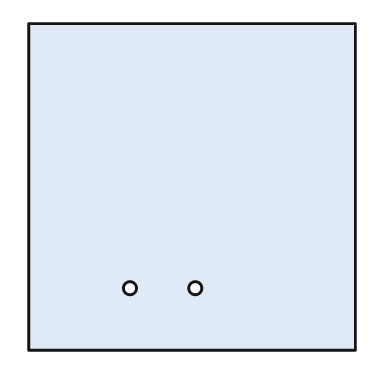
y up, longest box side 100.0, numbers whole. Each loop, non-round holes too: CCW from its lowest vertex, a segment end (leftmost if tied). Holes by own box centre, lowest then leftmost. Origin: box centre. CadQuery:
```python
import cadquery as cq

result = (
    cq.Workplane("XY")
    .moveTo(-50.0, -50.0)
    .lineTo(50.0, -50.0)
    .lineTo(50.0, 50.0)
    .lineTo(-50.0, 50.0)
    .close()
    .moveTo(-19.0, -31.0)
    .circle(2.0)
    .moveTo(1.0, -31.0)
    .circle(2.0)
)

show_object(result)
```